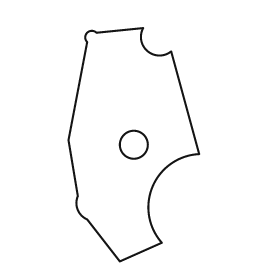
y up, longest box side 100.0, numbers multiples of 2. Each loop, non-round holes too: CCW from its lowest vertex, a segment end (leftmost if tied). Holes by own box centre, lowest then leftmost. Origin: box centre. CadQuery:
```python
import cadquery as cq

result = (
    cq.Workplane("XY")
    .moveTo(-6.0, -50.0)
    .lineTo(12.0, -42.0)
    .threePointArc((8.0, -18.0), (28.0, -4.0))
    .lineTo(16.0, 40.0)
    .threePointArc((6.0, 40.0), (4.0, 50.0))
    .lineTo(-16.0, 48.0)
    .threePointArc((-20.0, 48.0), (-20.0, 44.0))
    .lineTo(-28.0, 2.0)
    .lineTo(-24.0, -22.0)
    .threePointArc((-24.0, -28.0), (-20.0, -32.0))
    .close()
    .moveTo(0.0, 0.0)
    .circle(6.0)
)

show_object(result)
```